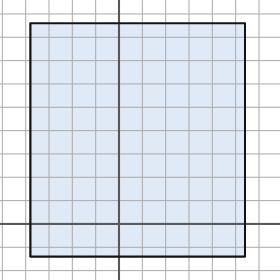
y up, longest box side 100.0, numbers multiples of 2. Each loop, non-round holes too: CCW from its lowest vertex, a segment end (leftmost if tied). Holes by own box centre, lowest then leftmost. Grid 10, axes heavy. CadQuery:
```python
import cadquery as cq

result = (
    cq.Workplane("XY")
    .moveTo(-38.0, -14.0)
    .lineTo(54.0, -14.0)
    .lineTo(54.0, 86.0)
    .lineTo(-38.0, 86.0)
    .close()
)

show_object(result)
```